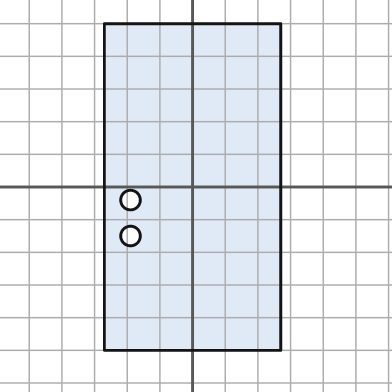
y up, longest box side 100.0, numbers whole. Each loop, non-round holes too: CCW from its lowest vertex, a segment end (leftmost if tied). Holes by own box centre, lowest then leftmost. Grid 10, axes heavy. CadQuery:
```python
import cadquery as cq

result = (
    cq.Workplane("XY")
    .moveTo(-27.0, -50.0)
    .lineTo(27.0, -50.0)
    .lineTo(27.0, 50.0)
    .lineTo(-27.0, 50.0)
    .close()
    .moveTo(-19.0, -15.0)
    .circle(3.0)
    .moveTo(-19.0, -4.0)
    .circle(3.0)
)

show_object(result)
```